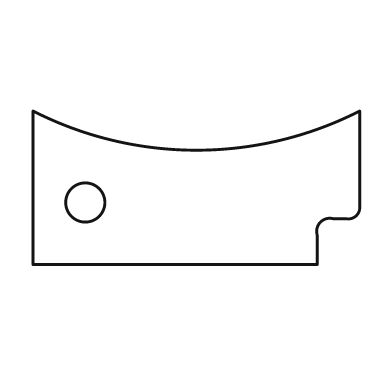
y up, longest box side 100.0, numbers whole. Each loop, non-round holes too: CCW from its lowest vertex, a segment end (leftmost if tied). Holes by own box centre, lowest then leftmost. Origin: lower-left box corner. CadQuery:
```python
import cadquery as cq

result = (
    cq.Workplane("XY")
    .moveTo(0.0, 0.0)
    .lineTo(87.0, 0.0)
    .lineTo(87.0, 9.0)
    .threePointArc((88.0, 13.0), (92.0, 14.0))
    .lineTo(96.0, 14.0)
    .threePointArc((99.0, 15.0), (100.0, 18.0))
    .lineTo(100.0, 47.0)
    .threePointArc((50.0, 35.0), (0.0, 47.0))
    .close()
    .moveTo(16.0, 19.0)
    .circle(6.0)
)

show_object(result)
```